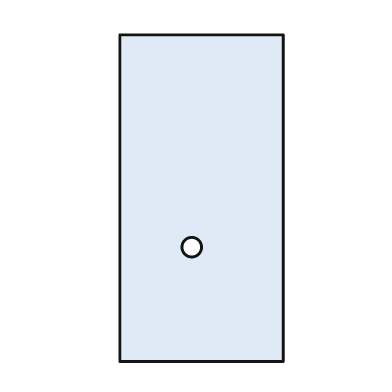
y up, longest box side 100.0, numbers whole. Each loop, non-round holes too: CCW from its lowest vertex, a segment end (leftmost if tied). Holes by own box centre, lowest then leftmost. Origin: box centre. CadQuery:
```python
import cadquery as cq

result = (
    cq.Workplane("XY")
    .moveTo(-25.0, -50.0)
    .lineTo(25.0, -50.0)
    .lineTo(25.0, 50.0)
    .lineTo(-25.0, 50.0)
    .close()
    .moveTo(-3.0, -15.0)
    .circle(3.0)
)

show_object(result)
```